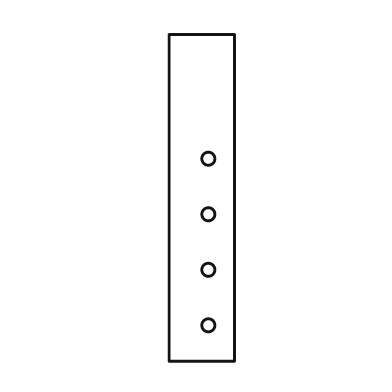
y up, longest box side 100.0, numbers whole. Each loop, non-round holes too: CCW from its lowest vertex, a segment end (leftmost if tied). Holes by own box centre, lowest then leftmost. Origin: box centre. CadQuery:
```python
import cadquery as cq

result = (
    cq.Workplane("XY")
    .moveTo(-10.0, -50.0)
    .lineTo(10.0, -50.0)
    .lineTo(10.0, 50.0)
    .lineTo(-10.0, 50.0)
    .close()
    .moveTo(2.0, -39.0)
    .circle(2.0)
    .moveTo(2.0, -22.0)
    .circle(2.0)
    .moveTo(2.0, -5.0)
    .circle(2.0)
    .moveTo(2.0, 12.0)
    .circle(2.0)
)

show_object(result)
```